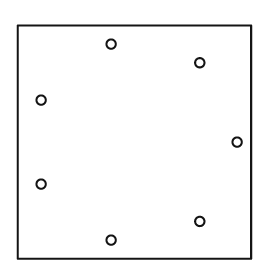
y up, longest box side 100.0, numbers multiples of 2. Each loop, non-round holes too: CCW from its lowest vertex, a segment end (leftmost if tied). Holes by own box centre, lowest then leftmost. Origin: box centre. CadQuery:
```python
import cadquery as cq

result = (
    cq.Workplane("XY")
    .moveTo(-50.0, -50.0)
    .lineTo(50.0, -50.0)
    .lineTo(50.0, 50.0)
    .lineTo(-50.0, 50.0)
    .close()
    .moveTo(-10.0, -42.0)
    .circle(2.0)
    .moveTo(28.0, -34.0)
    .circle(2.0)
    .moveTo(-40.0, -18.0)
    .circle(2.0)
    .moveTo(44.0, 0.0)
    .circle(2.0)
    .moveTo(-40.0, 18.0)
    .circle(2.0)
    .moveTo(28.0, 34.0)
    .circle(2.0)
    .moveTo(-10.0, 42.0)
    .circle(2.0)
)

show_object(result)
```